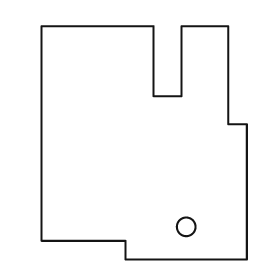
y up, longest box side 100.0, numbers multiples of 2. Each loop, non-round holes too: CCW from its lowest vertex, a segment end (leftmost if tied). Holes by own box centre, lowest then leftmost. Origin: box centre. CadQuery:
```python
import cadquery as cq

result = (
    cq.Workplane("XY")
    .moveTo(-8.0, -50.0)
    .lineTo(44.0, -50.0)
    .lineTo(44.0, 8.0)
    .lineTo(36.0, 8.0)
    .lineTo(36.0, 50.0)
    .lineTo(16.0, 50.0)
    .lineTo(16.0, 20.0)
    .lineTo(4.0, 20.0)
    .lineTo(4.0, 50.0)
    .lineTo(-44.0, 50.0)
    .lineTo(-44.0, -42.0)
    .lineTo(-8.0, -42.0)
    .close()
    .moveTo(18.0, -36.0)
    .circle(4.0)
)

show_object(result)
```